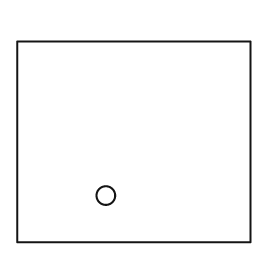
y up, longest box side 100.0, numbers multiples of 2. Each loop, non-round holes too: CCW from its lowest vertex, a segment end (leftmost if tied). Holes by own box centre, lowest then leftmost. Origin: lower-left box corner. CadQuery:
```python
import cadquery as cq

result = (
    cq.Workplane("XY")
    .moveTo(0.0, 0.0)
    .lineTo(100.0, 0.0)
    .lineTo(100.0, 86.0)
    .lineTo(0.0, 86.0)
    .close()
    .moveTo(38.0, 20.0)
    .circle(4.0)
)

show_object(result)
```